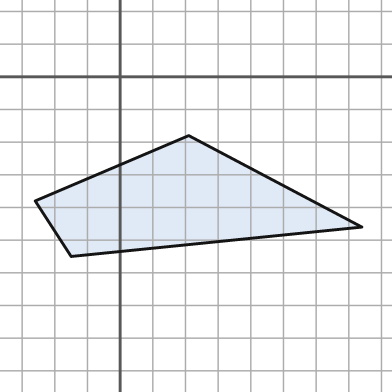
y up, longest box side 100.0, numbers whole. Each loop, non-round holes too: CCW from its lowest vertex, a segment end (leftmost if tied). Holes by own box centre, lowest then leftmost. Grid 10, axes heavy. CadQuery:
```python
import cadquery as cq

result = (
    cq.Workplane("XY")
    .moveTo(-15.0, -55.0)
    .lineTo(74.0, -46.0)
    .lineTo(21.0, -18.0)
    .lineTo(-26.0, -38.0)
    .close()
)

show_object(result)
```